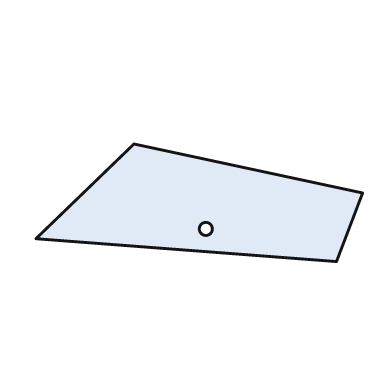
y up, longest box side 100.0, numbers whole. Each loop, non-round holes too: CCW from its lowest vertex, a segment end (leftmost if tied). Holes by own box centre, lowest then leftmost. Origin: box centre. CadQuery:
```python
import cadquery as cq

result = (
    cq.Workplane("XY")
    .moveTo(42.0, -18.0)
    .lineTo(50.0, 3.0)
    .lineTo(-20.0, 18.0)
    .lineTo(-50.0, -11.0)
    .close()
    .moveTo(2.0, -8.0)
    .circle(2.0)
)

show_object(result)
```